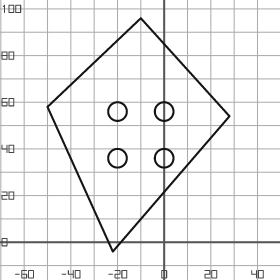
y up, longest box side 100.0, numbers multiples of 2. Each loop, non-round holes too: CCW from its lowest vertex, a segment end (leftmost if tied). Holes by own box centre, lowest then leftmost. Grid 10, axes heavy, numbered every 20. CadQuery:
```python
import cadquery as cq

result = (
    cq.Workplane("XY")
    .moveTo(-22.0, -4.0)
    .lineTo(28.0, 54.0)
    .lineTo(-10.0, 96.0)
    .lineTo(-50.0, 58.0)
    .close()
    .moveTo(-20.0, 36.0)
    .circle(4.0)
    .moveTo(0.0, 36.0)
    .circle(4.0)
    .moveTo(-20.0, 56.0)
    .circle(4.0)
    .moveTo(0.0, 56.0)
    .circle(4.0)
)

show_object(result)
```